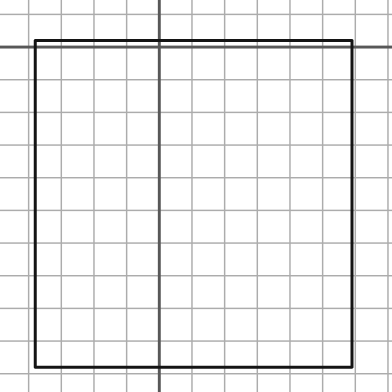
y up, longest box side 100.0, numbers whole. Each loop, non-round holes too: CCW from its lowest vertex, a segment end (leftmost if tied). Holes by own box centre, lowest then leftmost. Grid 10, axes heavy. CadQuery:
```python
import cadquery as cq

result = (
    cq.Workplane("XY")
    .moveTo(-38.0, -98.0)
    .lineTo(59.0, -98.0)
    .lineTo(59.0, 2.0)
    .lineTo(-38.0, 2.0)
    .close()
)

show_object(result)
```